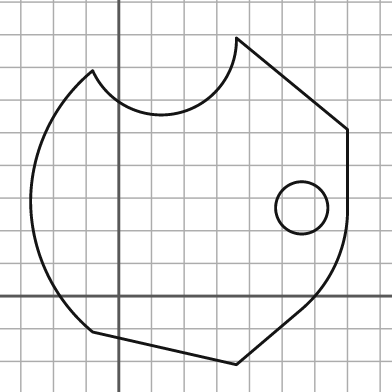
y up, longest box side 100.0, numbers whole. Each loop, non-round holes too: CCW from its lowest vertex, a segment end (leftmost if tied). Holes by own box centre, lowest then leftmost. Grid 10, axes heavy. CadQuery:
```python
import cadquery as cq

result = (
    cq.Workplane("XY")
    .moveTo(36.0, -21.0)
    .lineTo(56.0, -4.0)
    .threePointArc((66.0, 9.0), (70.0, 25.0))
    .lineTo(70.0, 51.0)
    .lineTo(36.0, 79.0)
    .threePointArc((18.0, 56.0), (-8.0, 69.0))
    .threePointArc((-22.0, 51.0), (-27.0, 29.0))
    .threePointArc((-22.0, 7.0), (-8.0, -11.0))
    .close()
    .moveTo(56.0, 27.0)
    .circle(8.0)
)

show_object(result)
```